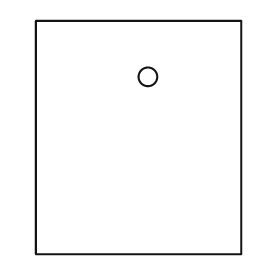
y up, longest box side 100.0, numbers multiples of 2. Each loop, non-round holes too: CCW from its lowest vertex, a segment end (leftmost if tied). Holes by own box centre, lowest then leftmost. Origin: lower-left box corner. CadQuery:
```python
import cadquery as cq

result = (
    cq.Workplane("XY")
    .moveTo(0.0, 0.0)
    .lineTo(88.0, 0.0)
    .lineTo(88.0, 100.0)
    .lineTo(0.0, 100.0)
    .close()
    .moveTo(48.0, 76.0)
    .circle(4.0)
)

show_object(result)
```